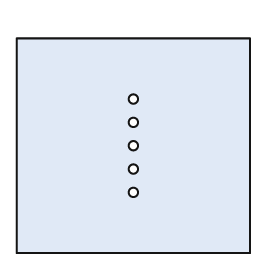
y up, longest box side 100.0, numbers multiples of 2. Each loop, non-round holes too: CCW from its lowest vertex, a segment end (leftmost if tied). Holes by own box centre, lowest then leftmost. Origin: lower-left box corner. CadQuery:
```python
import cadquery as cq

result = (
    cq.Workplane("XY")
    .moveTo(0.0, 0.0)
    .lineTo(100.0, 0.0)
    .lineTo(100.0, 92.0)
    .lineTo(0.0, 92.0)
    .close()
    .moveTo(50.0, 26.0)
    .circle(2.0)
    .moveTo(50.0, 36.0)
    .circle(2.0)
    .moveTo(50.0, 46.0)
    .circle(2.0)
    .moveTo(50.0, 56.0)
    .circle(2.0)
    .moveTo(50.0, 66.0)
    .circle(2.0)
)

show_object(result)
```